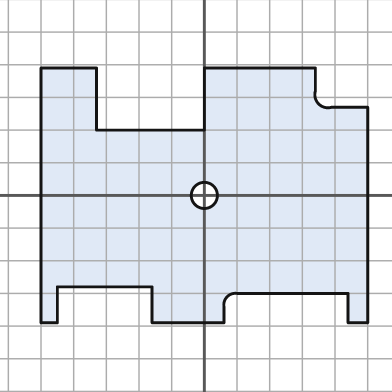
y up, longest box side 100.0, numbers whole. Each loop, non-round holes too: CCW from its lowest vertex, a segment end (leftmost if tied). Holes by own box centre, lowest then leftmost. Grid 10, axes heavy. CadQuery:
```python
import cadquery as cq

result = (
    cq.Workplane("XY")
    .moveTo(-50.0, -39.0)
    .lineTo(-45.0, -39.0)
    .lineTo(-45.0, -28.0)
    .lineTo(-16.0, -28.0)
    .lineTo(-16.0, -39.0)
    .lineTo(6.0, -39.0)
    .lineTo(6.0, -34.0)
    .threePointArc((7.0, -31.0), (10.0, -30.0))
    .lineTo(44.0, -30.0)
    .lineTo(44.0, -39.0)
    .lineTo(50.0, -39.0)
    .lineTo(50.0, 27.0)
    .lineTo(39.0, 27.0)
    .threePointArc((35.0, 28.0), (34.0, 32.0))
    .lineTo(34.0, 39.0)
    .lineTo(0.0, 39.0)
    .lineTo(0.0, 20.0)
    .lineTo(-33.0, 20.0)
    .lineTo(-33.0, 39.0)
    .lineTo(-50.0, 39.0)
    .close()
    .moveTo(0.0, 0.0)
    .circle(4.0)
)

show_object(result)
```